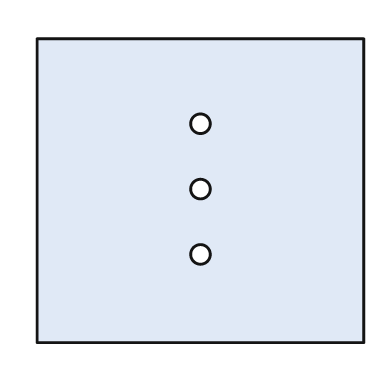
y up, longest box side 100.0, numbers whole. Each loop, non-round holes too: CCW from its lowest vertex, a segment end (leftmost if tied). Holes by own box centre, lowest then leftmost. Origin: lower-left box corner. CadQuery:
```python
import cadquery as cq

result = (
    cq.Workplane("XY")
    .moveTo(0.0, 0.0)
    .lineTo(100.0, 0.0)
    .lineTo(100.0, 93.0)
    .lineTo(0.0, 93.0)
    .close()
    .moveTo(50.0, 27.0)
    .circle(3.0)
    .moveTo(50.0, 47.0)
    .circle(3.0)
    .moveTo(50.0, 67.0)
    .circle(3.0)
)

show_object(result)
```